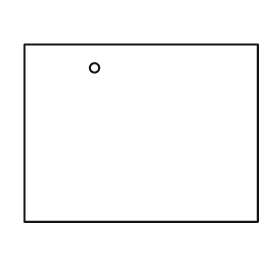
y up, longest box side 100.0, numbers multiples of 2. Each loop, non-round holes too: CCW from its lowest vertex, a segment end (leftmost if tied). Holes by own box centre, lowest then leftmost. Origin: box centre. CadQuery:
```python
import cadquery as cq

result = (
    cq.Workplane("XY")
    .moveTo(-50.0, -38.0)
    .lineTo(50.0, -38.0)
    .lineTo(50.0, 38.0)
    .lineTo(-50.0, 38.0)
    .close()
    .moveTo(-20.0, 28.0)
    .circle(2.0)
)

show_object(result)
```